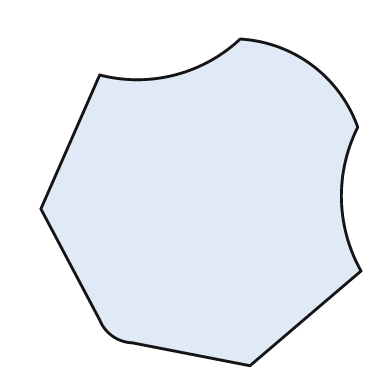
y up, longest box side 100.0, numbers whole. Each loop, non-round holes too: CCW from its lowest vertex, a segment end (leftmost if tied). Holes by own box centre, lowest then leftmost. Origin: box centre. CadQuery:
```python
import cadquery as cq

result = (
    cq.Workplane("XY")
    .moveTo(15.0, -50.0)
    .lineTo(49.0, -21.0)
    .threePointArc((43.0, 1.0), (48.0, 23.0))
    .threePointArc((34.0, 42.0), (12.0, 50.0))
    .threePointArc((-8.0, 39.0), (-31.0, 39.0))
    .lineTo(-49.0, -2.0)
    .lineTo(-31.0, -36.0)
    .threePointArc((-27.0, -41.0), (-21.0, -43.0))
    .close()
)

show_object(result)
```